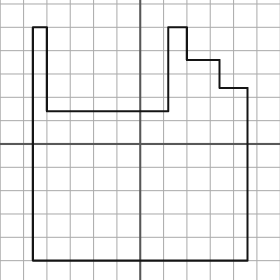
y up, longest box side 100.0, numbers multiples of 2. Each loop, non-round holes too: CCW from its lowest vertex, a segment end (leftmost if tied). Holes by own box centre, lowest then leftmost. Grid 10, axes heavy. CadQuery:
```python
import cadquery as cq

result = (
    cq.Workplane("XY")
    .moveTo(-46.0, -50.0)
    .lineTo(46.0, -50.0)
    .lineTo(46.0, 24.0)
    .lineTo(34.0, 24.0)
    .lineTo(34.0, 36.0)
    .lineTo(20.0, 36.0)
    .lineTo(20.0, 50.0)
    .lineTo(12.0, 50.0)
    .lineTo(12.0, 14.0)
    .lineTo(-40.0, 14.0)
    .lineTo(-40.0, 50.0)
    .lineTo(-46.0, 50.0)
    .close()
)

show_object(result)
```